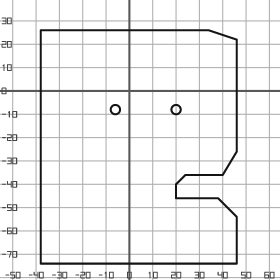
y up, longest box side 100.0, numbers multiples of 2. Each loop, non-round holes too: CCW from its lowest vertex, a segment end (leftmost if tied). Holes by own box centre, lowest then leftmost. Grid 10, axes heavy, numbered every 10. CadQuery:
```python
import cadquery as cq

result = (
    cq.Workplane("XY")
    .moveTo(-38.0, -74.0)
    .lineTo(46.0, -74.0)
    .lineTo(46.0, -54.0)
    .lineTo(38.0, -46.0)
    .lineTo(20.0, -46.0)
    .lineTo(20.0, -40.0)
    .lineTo(24.0, -36.0)
    .lineTo(40.0, -36.0)
    .lineTo(46.0, -26.0)
    .lineTo(46.0, 22.0)
    .lineTo(34.0, 26.0)
    .lineTo(-38.0, 26.0)
    .close()
    .moveTo(-6.0, -8.0)
    .circle(2.0)
    .moveTo(20.0, -8.0)
    .circle(2.0)
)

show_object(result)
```